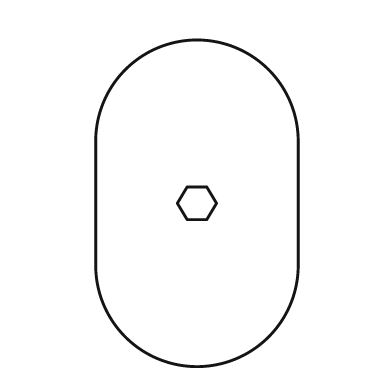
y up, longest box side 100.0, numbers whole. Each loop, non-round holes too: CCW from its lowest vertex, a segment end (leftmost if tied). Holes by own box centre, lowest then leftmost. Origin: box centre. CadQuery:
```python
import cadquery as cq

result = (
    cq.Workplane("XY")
    .moveTo(-31.0, -19.0)
    .threePointArc((0.0, -50.0), (31.0, -19.0))
    .lineTo(31.0, 19.0)
    .threePointArc((0.0, 50.0), (-31.0, 19.0))
    .close()
    .moveTo(-3.0, -5.0)
    .lineTo(3.0, -5.0)
    .lineTo(6.0, 0.0)
    .lineTo(3.0, 5.0)
    .lineTo(-3.0, 5.0)
    .lineTo(-6.0, 0.0)
    .close()
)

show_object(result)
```